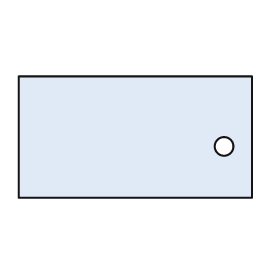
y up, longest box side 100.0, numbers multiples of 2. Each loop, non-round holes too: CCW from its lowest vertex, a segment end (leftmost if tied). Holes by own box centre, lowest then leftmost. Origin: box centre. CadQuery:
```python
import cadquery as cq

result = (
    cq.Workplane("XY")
    .moveTo(-50.0, -26.0)
    .lineTo(50.0, -26.0)
    .lineTo(50.0, 26.0)
    .lineTo(-50.0, 26.0)
    .close()
    .moveTo(38.0, -4.0)
    .circle(4.0)
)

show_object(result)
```